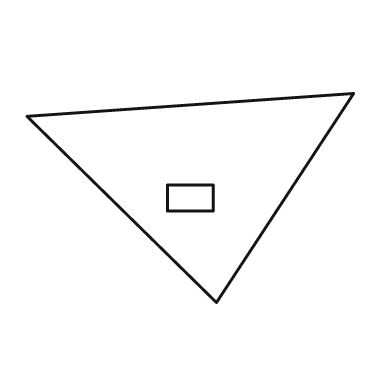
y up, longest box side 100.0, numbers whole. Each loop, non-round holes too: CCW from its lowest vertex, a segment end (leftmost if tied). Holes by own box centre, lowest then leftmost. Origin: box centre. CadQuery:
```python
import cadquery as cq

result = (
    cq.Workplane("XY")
    .moveTo(8.0, -32.0)
    .lineTo(50.0, 32.0)
    .lineTo(-50.0, 25.0)
    .close()
    .moveTo(-7.0, -4.0)
    .lineTo(7.0, -4.0)
    .lineTo(7.0, 4.0)
    .lineTo(-7.0, 4.0)
    .close()
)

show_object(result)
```